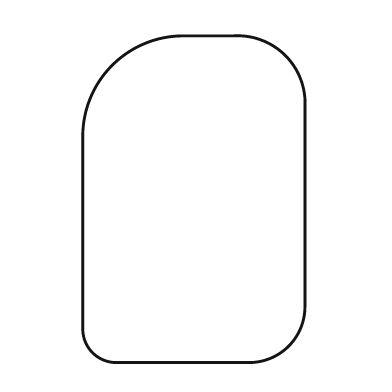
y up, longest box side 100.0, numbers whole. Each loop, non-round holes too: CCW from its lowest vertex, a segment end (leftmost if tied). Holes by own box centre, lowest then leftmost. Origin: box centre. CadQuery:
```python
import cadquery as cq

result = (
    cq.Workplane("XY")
    .moveTo(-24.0, -50.0)
    .lineTo(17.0, -50.0)
    .threePointArc((29.0, -45.0), (34.0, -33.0))
    .lineTo(34.0, 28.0)
    .threePointArc((28.0, 44.0), (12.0, 50.0))
    .lineTo(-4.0, 50.0)
    .threePointArc((-25.0, 41.0), (-34.0, 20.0))
    .lineTo(-34.0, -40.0)
    .threePointArc((-31.0, -47.0), (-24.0, -50.0))
    .close()
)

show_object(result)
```